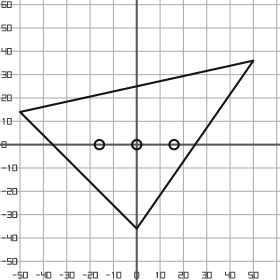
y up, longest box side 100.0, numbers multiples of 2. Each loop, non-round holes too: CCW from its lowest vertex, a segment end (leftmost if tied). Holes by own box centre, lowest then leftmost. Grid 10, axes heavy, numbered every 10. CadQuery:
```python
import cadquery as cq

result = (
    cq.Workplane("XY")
    .moveTo(0.0, -36.0)
    .lineTo(50.0, 36.0)
    .lineTo(-50.0, 14.0)
    .close()
    .moveTo(-16.0, 0.0)
    .circle(2.0)
    .moveTo(0.0, 0.0)
    .circle(2.0)
    .moveTo(16.0, 0.0)
    .circle(2.0)
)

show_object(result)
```